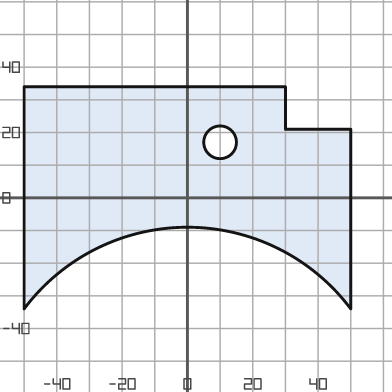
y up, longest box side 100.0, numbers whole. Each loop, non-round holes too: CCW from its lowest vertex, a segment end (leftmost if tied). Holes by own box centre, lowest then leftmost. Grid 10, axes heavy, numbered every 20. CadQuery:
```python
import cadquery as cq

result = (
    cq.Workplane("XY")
    .moveTo(-50.0, -34.0)
    .threePointArc((0.0, -9.0), (50.0, -34.0))
    .lineTo(50.0, 21.0)
    .lineTo(30.0, 21.0)
    .lineTo(30.0, 34.0)
    .lineTo(-50.0, 34.0)
    .close()
    .moveTo(10.0, 17.0)
    .circle(5.0)
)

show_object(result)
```